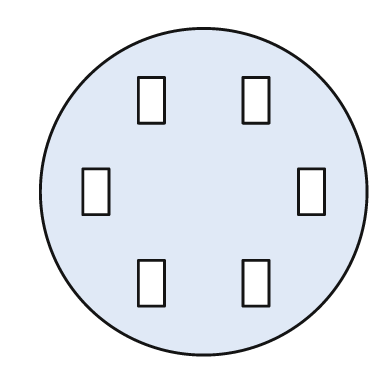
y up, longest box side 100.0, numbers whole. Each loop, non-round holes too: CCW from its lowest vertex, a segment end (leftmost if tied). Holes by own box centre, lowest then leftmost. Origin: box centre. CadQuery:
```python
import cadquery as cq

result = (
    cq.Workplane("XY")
    .moveTo(0.0, 0.0)
    .circle(50.0)
    .moveTo(-20.0, -35.0)
    .lineTo(-12.0, -35.0)
    .lineTo(-12.0, -21.0)
    .lineTo(-20.0, -21.0)
    .close()
    .moveTo(12.0, -35.0)
    .lineTo(20.0, -35.0)
    .lineTo(20.0, -21.0)
    .lineTo(12.0, -21.0)
    .close()
    .moveTo(-37.0, -7.0)
    .lineTo(-29.0, -7.0)
    .lineTo(-29.0, 7.0)
    .lineTo(-37.0, 7.0)
    .close()
    .moveTo(29.0, -7.0)
    .lineTo(37.0, -7.0)
    .lineTo(37.0, 7.0)
    .lineTo(29.0, 7.0)
    .close()
    .moveTo(-20.0, 21.0)
    .lineTo(-12.0, 21.0)
    .lineTo(-12.0, 35.0)
    .lineTo(-20.0, 35.0)
    .close()
    .moveTo(12.0, 21.0)
    .lineTo(20.0, 21.0)
    .lineTo(20.0, 35.0)
    .lineTo(12.0, 35.0)
    .close()
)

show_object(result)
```